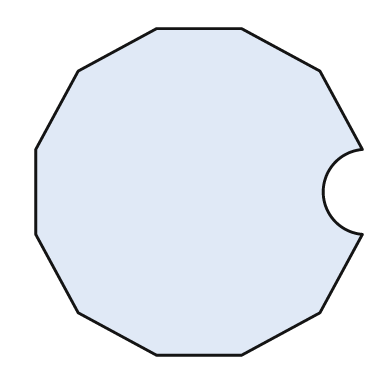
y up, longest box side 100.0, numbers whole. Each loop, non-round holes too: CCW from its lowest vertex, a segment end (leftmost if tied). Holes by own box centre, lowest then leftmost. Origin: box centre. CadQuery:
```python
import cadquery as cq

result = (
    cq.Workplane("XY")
    .moveTo(-13.0, -50.0)
    .lineTo(13.0, -50.0)
    .lineTo(37.0, -37.0)
    .lineTo(50.0, -13.0)
    .threePointArc((38.0, 0.0), (50.0, 13.0))
    .lineTo(37.0, 37.0)
    .lineTo(13.0, 50.0)
    .lineTo(-13.0, 50.0)
    .lineTo(-37.0, 37.0)
    .lineTo(-50.0, 13.0)
    .lineTo(-50.0, -13.0)
    .lineTo(-37.0, -37.0)
    .close()
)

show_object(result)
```